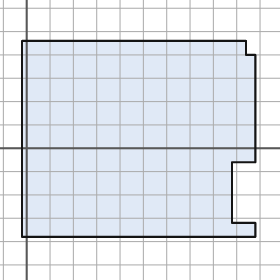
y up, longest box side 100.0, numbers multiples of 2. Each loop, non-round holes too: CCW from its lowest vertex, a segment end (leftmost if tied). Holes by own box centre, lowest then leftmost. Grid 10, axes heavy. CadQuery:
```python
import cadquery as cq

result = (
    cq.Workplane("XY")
    .moveTo(-2.0, -38.0)
    .lineTo(98.0, -38.0)
    .lineTo(98.0, -32.0)
    .lineTo(88.0, -32.0)
    .lineTo(88.0, -6.0)
    .lineTo(98.0, -6.0)
    .lineTo(98.0, 40.0)
    .lineTo(94.0, 40.0)
    .lineTo(94.0, 46.0)
    .lineTo(-2.0, 46.0)
    .close()
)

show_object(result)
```